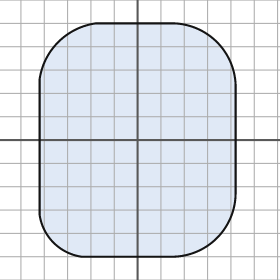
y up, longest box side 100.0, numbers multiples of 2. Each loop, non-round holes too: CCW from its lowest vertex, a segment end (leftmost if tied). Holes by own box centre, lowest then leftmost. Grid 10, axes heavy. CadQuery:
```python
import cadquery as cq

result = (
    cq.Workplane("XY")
    .moveTo(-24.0, -50.0)
    .lineTo(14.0, -50.0)
    .threePointArc((34.0, -42.0), (42.0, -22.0))
    .lineTo(42.0, 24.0)
    .threePointArc((34.0, 42.0), (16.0, 50.0))
    .lineTo(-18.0, 50.0)
    .threePointArc((-34.0, 42.0), (-42.0, 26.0))
    .lineTo(-42.0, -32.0)
    .threePointArc((-36.0, -44.0), (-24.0, -50.0))
    .close()
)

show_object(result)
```